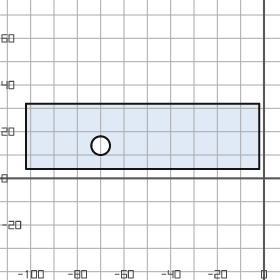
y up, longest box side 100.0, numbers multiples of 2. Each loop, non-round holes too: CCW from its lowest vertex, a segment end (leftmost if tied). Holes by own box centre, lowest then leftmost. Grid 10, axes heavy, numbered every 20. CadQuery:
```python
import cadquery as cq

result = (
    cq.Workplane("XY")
    .moveTo(-102.0, 4.0)
    .lineTo(-2.0, 4.0)
    .lineTo(-2.0, 32.0)
    .lineTo(-102.0, 32.0)
    .close()
    .moveTo(-70.0, 14.0)
    .circle(4.0)
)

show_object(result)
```